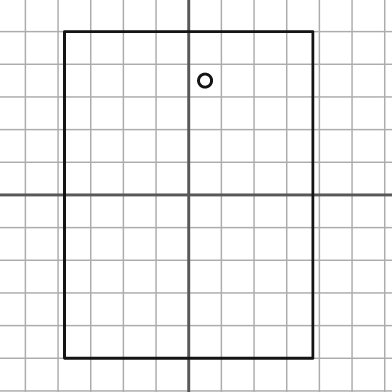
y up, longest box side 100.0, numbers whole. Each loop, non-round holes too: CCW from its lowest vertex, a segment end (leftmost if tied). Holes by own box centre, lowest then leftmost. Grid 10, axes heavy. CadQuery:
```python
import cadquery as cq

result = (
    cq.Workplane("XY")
    .moveTo(-38.0, -50.0)
    .lineTo(38.0, -50.0)
    .lineTo(38.0, 50.0)
    .lineTo(-38.0, 50.0)
    .close()
    .moveTo(5.0, 35.0)
    .circle(2.0)
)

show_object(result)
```